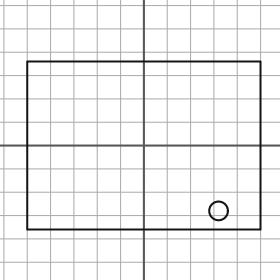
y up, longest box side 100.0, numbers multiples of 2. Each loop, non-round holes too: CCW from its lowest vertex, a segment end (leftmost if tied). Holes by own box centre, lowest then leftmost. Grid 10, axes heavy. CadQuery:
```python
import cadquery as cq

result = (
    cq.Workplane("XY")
    .moveTo(-50.0, -36.0)
    .lineTo(50.0, -36.0)
    .lineTo(50.0, 36.0)
    .lineTo(-50.0, 36.0)
    .close()
    .moveTo(32.0, -28.0)
    .circle(4.0)
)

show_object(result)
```